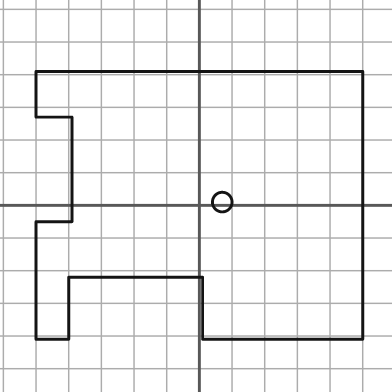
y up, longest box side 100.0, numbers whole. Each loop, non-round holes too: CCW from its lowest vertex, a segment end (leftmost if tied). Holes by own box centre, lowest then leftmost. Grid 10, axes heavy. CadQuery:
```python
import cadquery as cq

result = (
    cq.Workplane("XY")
    .moveTo(-50.0, -41.0)
    .lineTo(-40.0, -41.0)
    .lineTo(-40.0, -22.0)
    .lineTo(1.0, -22.0)
    .lineTo(1.0, -41.0)
    .lineTo(50.0, -41.0)
    .lineTo(50.0, 41.0)
    .lineTo(-50.0, 41.0)
    .lineTo(-50.0, 27.0)
    .lineTo(-39.0, 27.0)
    .lineTo(-39.0, -5.0)
    .lineTo(-50.0, -5.0)
    .close()
    .moveTo(7.0, 1.0)
    .circle(3.0)
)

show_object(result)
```